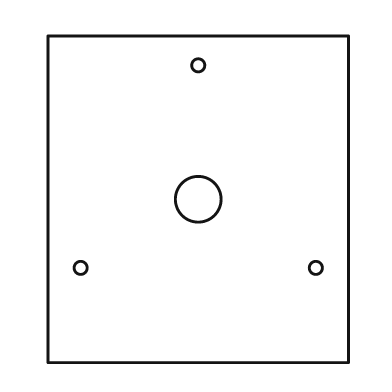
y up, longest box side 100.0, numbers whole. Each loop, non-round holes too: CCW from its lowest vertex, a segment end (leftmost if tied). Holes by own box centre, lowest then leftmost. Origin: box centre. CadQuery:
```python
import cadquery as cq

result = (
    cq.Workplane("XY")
    .moveTo(-46.0, -50.0)
    .lineTo(46.0, -50.0)
    .lineTo(46.0, 50.0)
    .lineTo(-46.0, 50.0)
    .close()
    .moveTo(-36.0, -21.0)
    .circle(2.0)
    .moveTo(36.0, -21.0)
    .circle(2.0)
    .moveTo(0.0, 0.0)
    .circle(7.0)
    .moveTo(0.0, 41.0)
    .circle(2.0)
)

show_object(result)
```